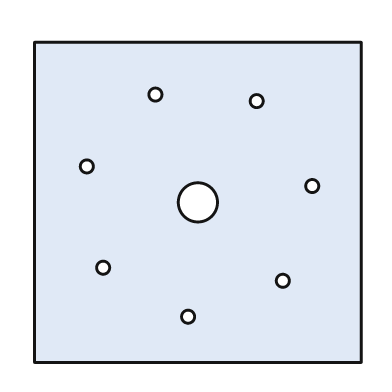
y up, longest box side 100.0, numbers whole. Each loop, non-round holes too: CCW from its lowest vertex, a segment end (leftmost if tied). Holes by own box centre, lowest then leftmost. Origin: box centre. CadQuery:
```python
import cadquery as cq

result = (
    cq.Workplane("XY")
    .moveTo(-50.0, -49.0)
    .lineTo(50.0, -49.0)
    .lineTo(50.0, 49.0)
    .lineTo(-50.0, 49.0)
    .close()
    .moveTo(-3.0, -35.0)
    .circle(2.0)
    .moveTo(26.0, -24.0)
    .circle(2.0)
    .moveTo(-29.0, -20.0)
    .circle(2.0)
    .moveTo(0.0, 0.0)
    .circle(6.0)
    .moveTo(35.0, 5.0)
    .circle(2.0)
    .moveTo(-34.0, 11.0)
    .circle(2.0)
    .moveTo(18.0, 31.0)
    .circle(2.0)
    .moveTo(-13.0, 33.0)
    .circle(2.0)
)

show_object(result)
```